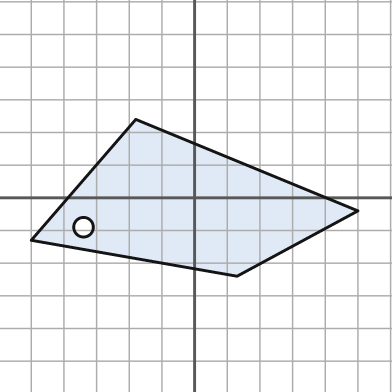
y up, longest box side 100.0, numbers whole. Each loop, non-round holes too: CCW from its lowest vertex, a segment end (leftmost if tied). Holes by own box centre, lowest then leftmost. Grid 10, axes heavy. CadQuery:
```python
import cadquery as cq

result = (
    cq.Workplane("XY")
    .moveTo(13.0, -24.0)
    .lineTo(50.0, -4.0)
    .lineTo(-18.0, 24.0)
    .lineTo(-50.0, -13.0)
    .close()
    .moveTo(-34.0, -9.0)
    .circle(3.0)
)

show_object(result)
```